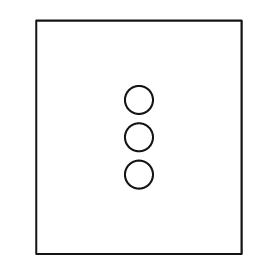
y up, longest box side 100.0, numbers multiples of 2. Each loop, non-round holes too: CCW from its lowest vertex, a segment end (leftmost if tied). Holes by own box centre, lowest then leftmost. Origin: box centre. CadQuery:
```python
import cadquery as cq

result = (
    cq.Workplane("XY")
    .moveTo(-44.0, -50.0)
    .lineTo(44.0, -50.0)
    .lineTo(44.0, 50.0)
    .lineTo(-44.0, 50.0)
    .close()
    .moveTo(0.0, -16.0)
    .circle(6.0)
    .moveTo(0.0, 0.0)
    .circle(6.0)
    .moveTo(0.0, 16.0)
    .circle(6.0)
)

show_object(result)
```